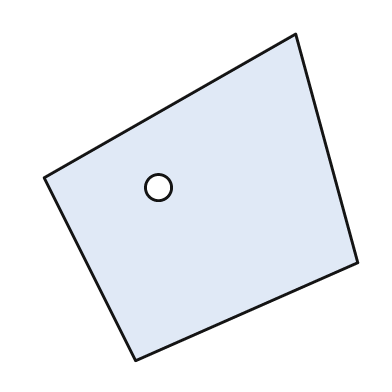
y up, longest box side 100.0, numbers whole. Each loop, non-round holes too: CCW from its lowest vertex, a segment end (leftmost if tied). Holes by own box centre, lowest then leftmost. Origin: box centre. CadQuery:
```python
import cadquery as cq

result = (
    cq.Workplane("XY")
    .moveTo(-20.0, -50.0)
    .lineTo(48.0, -20.0)
    .lineTo(29.0, 50.0)
    .lineTo(-48.0, 6.0)
    .close()
    .moveTo(-13.0, 3.0)
    .circle(4.0)
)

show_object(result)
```